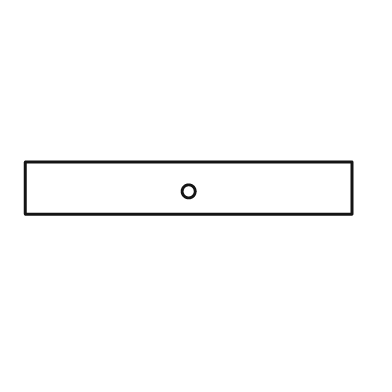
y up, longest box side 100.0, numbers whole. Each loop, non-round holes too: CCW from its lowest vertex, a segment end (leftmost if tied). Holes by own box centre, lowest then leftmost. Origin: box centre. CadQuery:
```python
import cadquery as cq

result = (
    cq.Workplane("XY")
    .moveTo(-50.0, -8.0)
    .lineTo(50.0, -8.0)
    .lineTo(50.0, 8.0)
    .lineTo(-50.0, 8.0)
    .close()
    .moveTo(0.0, -1.0)
    .circle(2.0)
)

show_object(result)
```